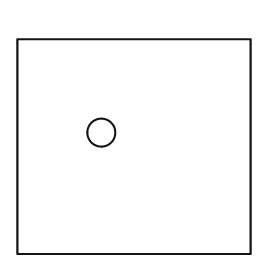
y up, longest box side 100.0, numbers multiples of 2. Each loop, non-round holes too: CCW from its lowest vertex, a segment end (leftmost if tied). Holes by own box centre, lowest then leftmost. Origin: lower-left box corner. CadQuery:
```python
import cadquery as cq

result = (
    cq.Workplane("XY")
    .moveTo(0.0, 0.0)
    .lineTo(100.0, 0.0)
    .lineTo(100.0, 92.0)
    .lineTo(0.0, 92.0)
    .close()
    .moveTo(36.0, 52.0)
    .circle(6.0)
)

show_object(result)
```